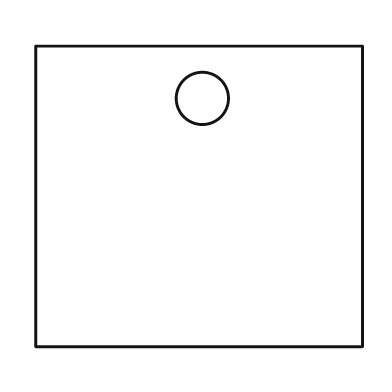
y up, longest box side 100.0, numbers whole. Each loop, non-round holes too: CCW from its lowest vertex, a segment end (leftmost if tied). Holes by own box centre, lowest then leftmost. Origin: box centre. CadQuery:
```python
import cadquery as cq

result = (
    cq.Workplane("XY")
    .moveTo(-50.0, -46.0)
    .lineTo(50.0, -46.0)
    .lineTo(50.0, 46.0)
    .lineTo(-50.0, 46.0)
    .close()
    .moveTo(1.0, 30.0)
    .circle(8.0)
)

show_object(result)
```